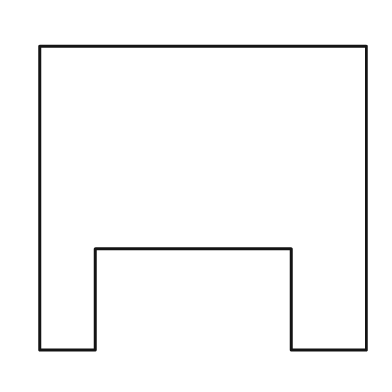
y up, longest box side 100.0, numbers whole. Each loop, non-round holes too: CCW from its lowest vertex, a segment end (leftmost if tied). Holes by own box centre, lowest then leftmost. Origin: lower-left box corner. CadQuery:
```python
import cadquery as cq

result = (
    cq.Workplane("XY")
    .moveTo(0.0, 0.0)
    .lineTo(17.0, 0.0)
    .lineTo(17.0, 31.0)
    .lineTo(77.0, 31.0)
    .lineTo(77.0, 0.0)
    .lineTo(100.0, 0.0)
    .lineTo(100.0, 93.0)
    .lineTo(0.0, 93.0)
    .close()
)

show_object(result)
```